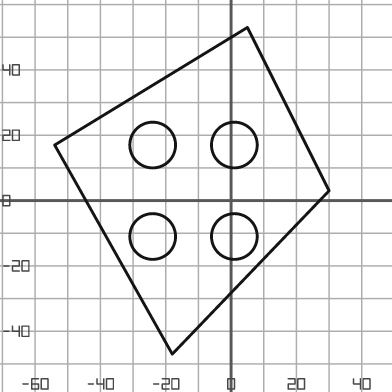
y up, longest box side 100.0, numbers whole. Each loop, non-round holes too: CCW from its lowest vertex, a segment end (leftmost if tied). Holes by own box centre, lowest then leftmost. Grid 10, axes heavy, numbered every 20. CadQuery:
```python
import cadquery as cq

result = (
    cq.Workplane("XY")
    .moveTo(-18.0, -47.0)
    .lineTo(30.0, 3.0)
    .lineTo(5.0, 53.0)
    .lineTo(-54.0, 17.0)
    .close()
    .moveTo(-24.0, -11.0)
    .circle(7.0)
    .moveTo(1.0, -11.0)
    .circle(7.0)
    .moveTo(-24.0, 17.0)
    .circle(7.0)
    .moveTo(1.0, 17.0)
    .circle(7.0)
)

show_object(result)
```